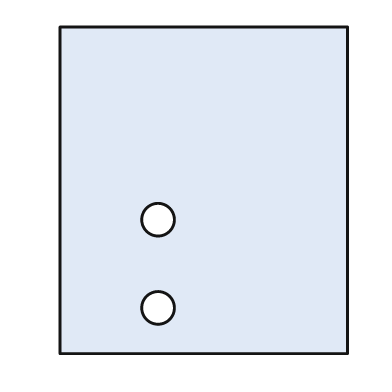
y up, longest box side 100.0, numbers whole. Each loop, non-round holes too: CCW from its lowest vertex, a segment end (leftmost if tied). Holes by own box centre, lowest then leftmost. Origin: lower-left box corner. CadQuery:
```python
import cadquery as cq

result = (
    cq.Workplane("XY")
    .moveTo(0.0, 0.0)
    .lineTo(88.0, 0.0)
    .lineTo(88.0, 100.0)
    .lineTo(0.0, 100.0)
    .close()
    .moveTo(30.0, 14.0)
    .circle(5.0)
    .moveTo(30.0, 41.0)
    .circle(5.0)
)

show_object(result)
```